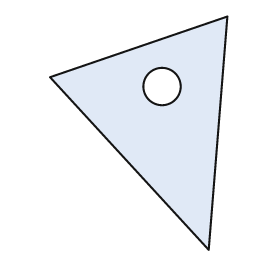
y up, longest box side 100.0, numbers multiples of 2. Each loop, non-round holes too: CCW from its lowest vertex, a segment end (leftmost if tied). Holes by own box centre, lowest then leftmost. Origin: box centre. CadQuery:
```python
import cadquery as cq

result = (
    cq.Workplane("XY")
    .moveTo(30.0, -50.0)
    .lineTo(38.0, 50.0)
    .lineTo(-38.0, 24.0)
    .close()
    .moveTo(10.0, 20.0)
    .circle(8.0)
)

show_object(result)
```